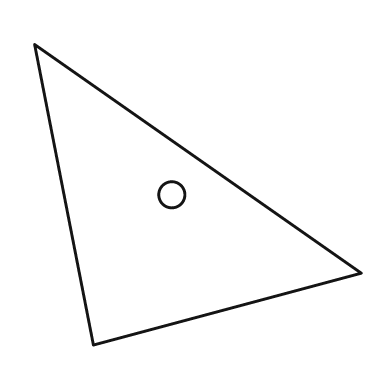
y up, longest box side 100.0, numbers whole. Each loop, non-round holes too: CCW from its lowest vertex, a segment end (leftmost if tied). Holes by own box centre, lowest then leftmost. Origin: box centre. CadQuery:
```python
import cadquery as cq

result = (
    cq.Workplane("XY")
    .moveTo(-32.0, -46.0)
    .lineTo(50.0, -24.0)
    .lineTo(-50.0, 46.0)
    .close()
    .moveTo(-8.0, 0.0)
    .circle(4.0)
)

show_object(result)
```